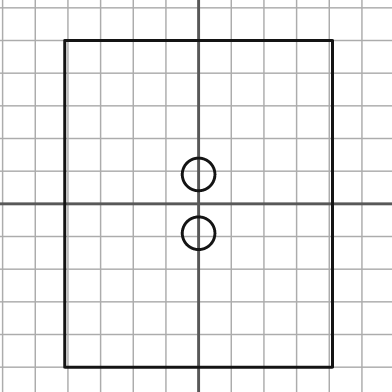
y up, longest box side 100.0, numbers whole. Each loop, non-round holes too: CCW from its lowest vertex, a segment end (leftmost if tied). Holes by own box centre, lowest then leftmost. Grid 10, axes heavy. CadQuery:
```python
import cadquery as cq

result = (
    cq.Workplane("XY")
    .moveTo(-41.0, -50.0)
    .lineTo(41.0, -50.0)
    .lineTo(41.0, 50.0)
    .lineTo(-41.0, 50.0)
    .close()
    .moveTo(0.0, -9.0)
    .circle(5.0)
    .moveTo(0.0, 9.0)
    .circle(5.0)
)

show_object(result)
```